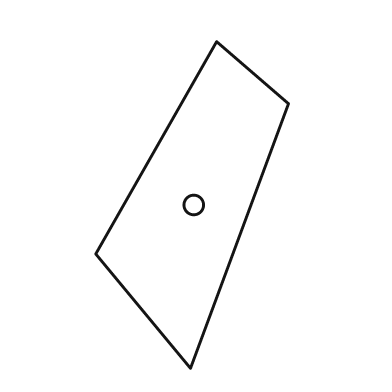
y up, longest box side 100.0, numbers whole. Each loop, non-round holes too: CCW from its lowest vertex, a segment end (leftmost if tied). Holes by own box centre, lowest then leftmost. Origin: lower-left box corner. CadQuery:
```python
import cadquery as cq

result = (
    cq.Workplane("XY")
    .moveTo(29.0, 0.0)
    .lineTo(59.0, 81.0)
    .lineTo(37.0, 100.0)
    .lineTo(0.0, 35.0)
    .close()
    .moveTo(30.0, 50.0)
    .circle(3.0)
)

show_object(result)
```